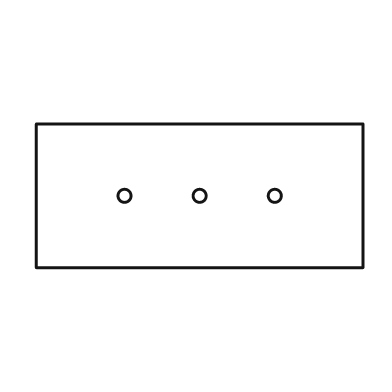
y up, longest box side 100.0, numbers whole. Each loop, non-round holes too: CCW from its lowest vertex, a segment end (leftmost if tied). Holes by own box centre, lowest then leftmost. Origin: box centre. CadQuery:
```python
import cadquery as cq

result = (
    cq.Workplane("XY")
    .moveTo(-50.0, -22.0)
    .lineTo(50.0, -22.0)
    .lineTo(50.0, 22.0)
    .lineTo(-50.0, 22.0)
    .close()
    .moveTo(-23.0, 0.0)
    .circle(2.0)
    .moveTo(0.0, 0.0)
    .circle(2.0)
    .moveTo(23.0, 0.0)
    .circle(2.0)
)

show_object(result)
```